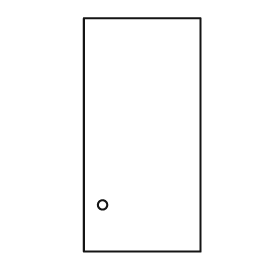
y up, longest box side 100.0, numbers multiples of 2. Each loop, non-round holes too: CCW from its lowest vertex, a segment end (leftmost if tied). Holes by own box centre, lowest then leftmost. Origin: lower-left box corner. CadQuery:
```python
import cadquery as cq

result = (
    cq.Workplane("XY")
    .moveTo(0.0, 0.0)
    .lineTo(50.0, 0.0)
    .lineTo(50.0, 100.0)
    .lineTo(0.0, 100.0)
    .close()
    .moveTo(8.0, 20.0)
    .circle(2.0)
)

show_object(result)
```